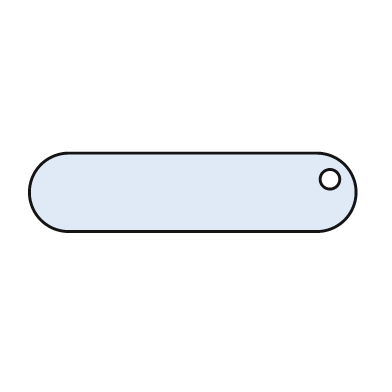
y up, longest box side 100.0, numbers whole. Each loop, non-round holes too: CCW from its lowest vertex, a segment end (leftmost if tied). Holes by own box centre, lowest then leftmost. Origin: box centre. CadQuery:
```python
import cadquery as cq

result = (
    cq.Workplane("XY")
    .moveTo(-38.0, -12.0)
    .lineTo(38.0, -12.0)
    .threePointArc((50.0, 0.0), (38.0, 12.0))
    .lineTo(-38.0, 12.0)
    .threePointArc((-50.0, 0.0), (-38.0, -12.0))
    .close()
    .moveTo(42.0, 4.0)
    .circle(3.0)
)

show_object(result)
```